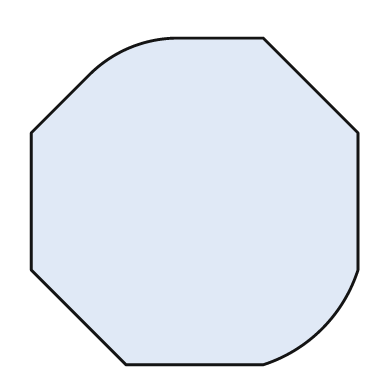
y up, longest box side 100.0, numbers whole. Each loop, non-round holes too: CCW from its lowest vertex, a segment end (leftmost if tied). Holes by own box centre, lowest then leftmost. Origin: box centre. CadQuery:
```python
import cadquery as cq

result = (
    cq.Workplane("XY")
    .moveTo(-21.0, -50.0)
    .lineTo(21.0, -50.0)
    .threePointArc((39.0, -39.0), (50.0, -21.0))
    .lineTo(50.0, 21.0)
    .lineTo(21.0, 50.0)
    .lineTo(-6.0, 50.0)
    .threePointArc((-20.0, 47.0), (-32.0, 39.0))
    .lineTo(-50.0, 21.0)
    .lineTo(-50.0, -21.0)
    .close()
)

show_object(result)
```